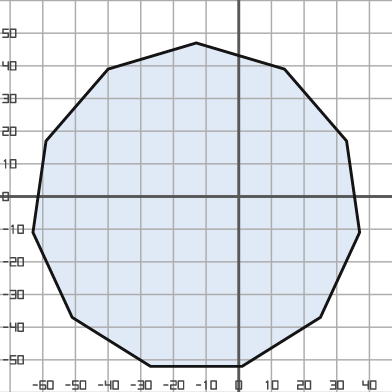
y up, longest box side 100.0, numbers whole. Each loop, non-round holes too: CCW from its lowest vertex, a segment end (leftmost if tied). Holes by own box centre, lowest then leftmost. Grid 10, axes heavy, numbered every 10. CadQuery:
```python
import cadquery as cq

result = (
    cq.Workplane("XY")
    .moveTo(-27.0, -52.0)
    .lineTo(1.0, -52.0)
    .lineTo(25.0, -37.0)
    .lineTo(37.0, -11.0)
    .lineTo(33.0, 17.0)
    .lineTo(14.0, 39.0)
    .lineTo(-13.0, 47.0)
    .lineTo(-40.0, 39.0)
    .lineTo(-59.0, 17.0)
    .lineTo(-63.0, -11.0)
    .lineTo(-51.0, -37.0)
    .close()
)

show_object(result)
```